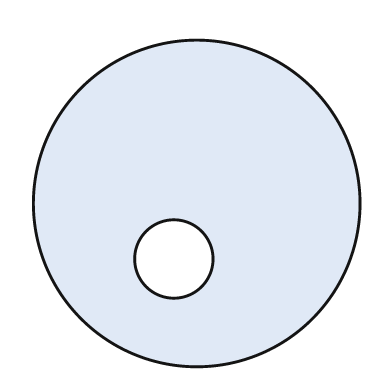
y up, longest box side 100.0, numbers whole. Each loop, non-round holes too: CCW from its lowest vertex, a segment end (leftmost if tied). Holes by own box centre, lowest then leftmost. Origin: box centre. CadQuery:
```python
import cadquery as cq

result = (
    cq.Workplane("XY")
    .moveTo(0.0, 0.0)
    .circle(50.0)
    .moveTo(-7.0, -17.0)
    .circle(12.0)
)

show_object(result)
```